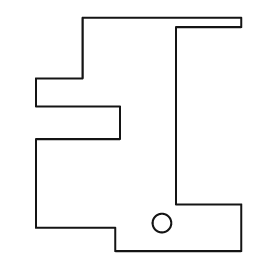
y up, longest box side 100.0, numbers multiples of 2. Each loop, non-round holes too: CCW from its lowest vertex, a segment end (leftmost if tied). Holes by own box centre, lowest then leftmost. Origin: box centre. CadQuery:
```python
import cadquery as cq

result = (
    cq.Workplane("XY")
    .moveTo(-10.0, -50.0)
    .lineTo(44.0, -50.0)
    .lineTo(44.0, -30.0)
    .lineTo(16.0, -30.0)
    .lineTo(16.0, 46.0)
    .lineTo(44.0, 46.0)
    .lineTo(44.0, 50.0)
    .lineTo(-24.0, 50.0)
    .lineTo(-24.0, 24.0)
    .lineTo(-44.0, 24.0)
    .lineTo(-44.0, 12.0)
    .lineTo(-8.0, 12.0)
    .lineTo(-8.0, -2.0)
    .lineTo(-44.0, -2.0)
    .lineTo(-44.0, -40.0)
    .lineTo(-10.0, -40.0)
    .close()
    .moveTo(10.0, -38.0)
    .circle(4.0)
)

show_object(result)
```